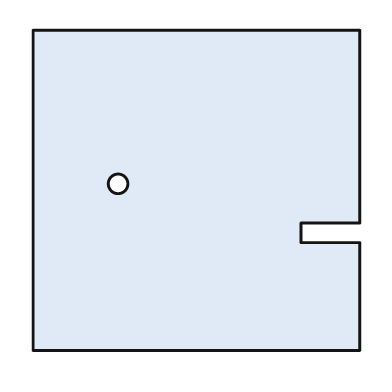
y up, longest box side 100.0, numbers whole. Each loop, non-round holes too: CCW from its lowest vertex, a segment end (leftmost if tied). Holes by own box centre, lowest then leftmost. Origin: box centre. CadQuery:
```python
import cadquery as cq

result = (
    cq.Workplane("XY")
    .moveTo(-50.0, -49.0)
    .lineTo(50.0, -49.0)
    .lineTo(50.0, -16.0)
    .lineTo(32.0, -16.0)
    .lineTo(32.0, -10.0)
    .lineTo(50.0, -10.0)
    .lineTo(50.0, 49.0)
    .lineTo(-50.0, 49.0)
    .close()
    .moveTo(-24.0, 2.0)
    .circle(3.0)
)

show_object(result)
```